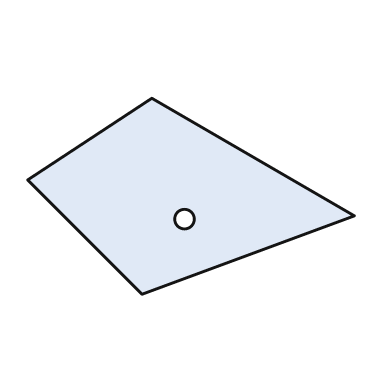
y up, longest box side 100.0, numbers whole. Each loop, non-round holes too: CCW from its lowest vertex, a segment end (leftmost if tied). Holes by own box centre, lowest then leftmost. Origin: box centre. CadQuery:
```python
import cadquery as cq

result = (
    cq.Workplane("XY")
    .moveTo(-15.0, -30.0)
    .lineTo(50.0, -6.0)
    .lineTo(-12.0, 30.0)
    .lineTo(-50.0, 5.0)
    .close()
    .moveTo(-2.0, -7.0)
    .circle(3.0)
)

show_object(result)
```